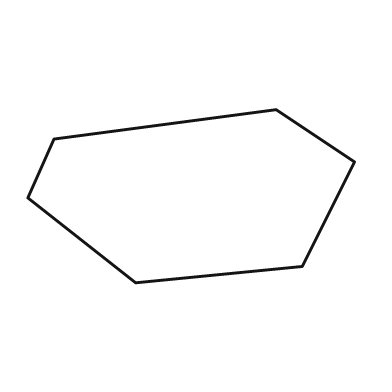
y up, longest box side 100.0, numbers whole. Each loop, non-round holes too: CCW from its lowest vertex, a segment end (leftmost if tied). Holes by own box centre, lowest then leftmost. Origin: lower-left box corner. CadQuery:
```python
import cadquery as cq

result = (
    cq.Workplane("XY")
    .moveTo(33.0, 0.0)
    .lineTo(84.0, 5.0)
    .lineTo(100.0, 37.0)
    .lineTo(76.0, 53.0)
    .lineTo(8.0, 44.0)
    .lineTo(0.0, 26.0)
    .close()
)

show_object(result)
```